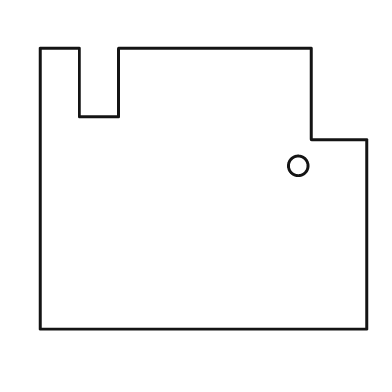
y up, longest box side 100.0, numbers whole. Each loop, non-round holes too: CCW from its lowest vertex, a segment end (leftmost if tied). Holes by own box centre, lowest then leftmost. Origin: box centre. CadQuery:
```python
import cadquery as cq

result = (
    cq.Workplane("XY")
    .moveTo(-50.0, -43.0)
    .lineTo(50.0, -43.0)
    .lineTo(50.0, 15.0)
    .lineTo(33.0, 15.0)
    .lineTo(33.0, 43.0)
    .lineTo(-26.0, 43.0)
    .lineTo(-26.0, 22.0)
    .lineTo(-38.0, 22.0)
    .lineTo(-38.0, 43.0)
    .lineTo(-50.0, 43.0)
    .close()
    .moveTo(29.0, 7.0)
    .circle(3.0)
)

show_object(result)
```